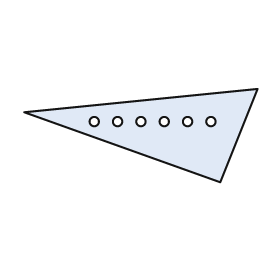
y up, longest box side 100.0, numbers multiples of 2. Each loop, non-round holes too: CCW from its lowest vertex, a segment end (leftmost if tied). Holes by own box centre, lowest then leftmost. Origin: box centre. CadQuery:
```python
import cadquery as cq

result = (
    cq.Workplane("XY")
    .moveTo(34.0, -20.0)
    .lineTo(50.0, 20.0)
    .lineTo(-50.0, 10.0)
    .close()
    .moveTo(-20.0, 6.0)
    .circle(2.0)
    .moveTo(-10.0, 6.0)
    .circle(2.0)
    .moveTo(0.0, 6.0)
    .circle(2.0)
    .moveTo(10.0, 6.0)
    .circle(2.0)
    .moveTo(20.0, 6.0)
    .circle(2.0)
    .moveTo(30.0, 6.0)
    .circle(2.0)
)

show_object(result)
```